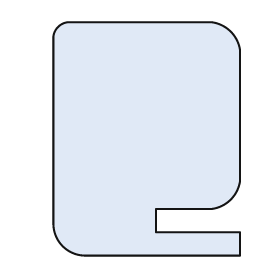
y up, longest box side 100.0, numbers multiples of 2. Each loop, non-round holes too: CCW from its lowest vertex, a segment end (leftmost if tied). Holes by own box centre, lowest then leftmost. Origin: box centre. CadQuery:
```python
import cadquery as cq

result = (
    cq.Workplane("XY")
    .moveTo(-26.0, -50.0)
    .lineTo(40.0, -50.0)
    .lineTo(40.0, -40.0)
    .lineTo(4.0, -40.0)
    .lineTo(4.0, -30.0)
    .lineTo(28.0, -30.0)
    .threePointArc((36.0, -26.0), (40.0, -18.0))
    .lineTo(40.0, 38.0)
    .threePointArc((36.0, 46.0), (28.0, 50.0))
    .lineTo(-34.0, 50.0)
    .threePointArc((-38.0, 48.0), (-40.0, 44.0))
    .lineTo(-40.0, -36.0)
    .threePointArc((-36.0, -46.0), (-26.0, -50.0))
    .close()
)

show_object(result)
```